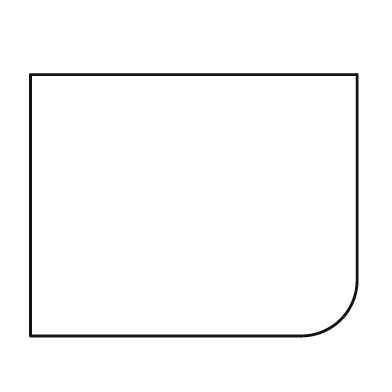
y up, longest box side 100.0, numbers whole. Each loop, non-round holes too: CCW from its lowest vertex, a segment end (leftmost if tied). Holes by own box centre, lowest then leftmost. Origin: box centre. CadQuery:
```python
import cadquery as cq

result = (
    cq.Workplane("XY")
    .moveTo(-50.0, -40.0)
    .lineTo(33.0, -40.0)
    .threePointArc((45.0, -35.0), (50.0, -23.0))
    .lineTo(50.0, 40.0)
    .lineTo(-50.0, 40.0)
    .close()
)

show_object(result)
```